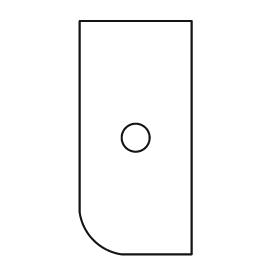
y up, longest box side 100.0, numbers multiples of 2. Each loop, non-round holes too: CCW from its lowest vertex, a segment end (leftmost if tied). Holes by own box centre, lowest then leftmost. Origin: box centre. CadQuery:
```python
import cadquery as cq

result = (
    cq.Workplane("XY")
    .moveTo(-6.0, -50.0)
    .lineTo(24.0, -50.0)
    .lineTo(24.0, 50.0)
    .lineTo(-24.0, 50.0)
    .lineTo(-24.0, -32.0)
    .threePointArc((-18.0, -44.0), (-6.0, -50.0))
    .close()
    .moveTo(0.0, 0.0)
    .circle(6.0)
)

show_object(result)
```